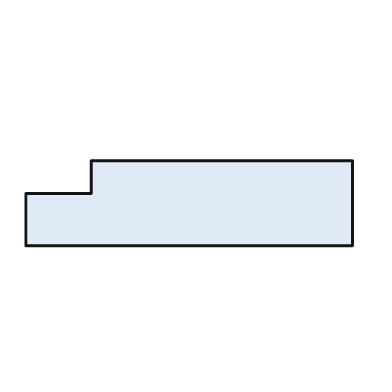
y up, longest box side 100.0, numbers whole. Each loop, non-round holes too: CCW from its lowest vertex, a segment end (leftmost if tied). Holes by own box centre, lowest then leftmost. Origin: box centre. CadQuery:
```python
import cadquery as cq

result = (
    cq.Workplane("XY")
    .moveTo(-50.0, -13.0)
    .lineTo(50.0, -13.0)
    .lineTo(50.0, 13.0)
    .lineTo(-30.0, 13.0)
    .lineTo(-30.0, 3.0)
    .lineTo(-50.0, 3.0)
    .close()
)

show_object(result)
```